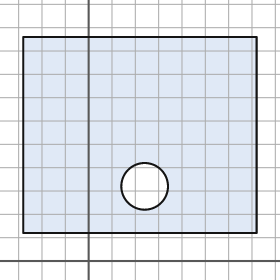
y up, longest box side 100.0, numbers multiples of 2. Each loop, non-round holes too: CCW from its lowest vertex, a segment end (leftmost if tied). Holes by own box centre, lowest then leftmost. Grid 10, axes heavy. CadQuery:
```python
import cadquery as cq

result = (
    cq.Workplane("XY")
    .moveTo(-28.0, 12.0)
    .lineTo(72.0, 12.0)
    .lineTo(72.0, 96.0)
    .lineTo(-28.0, 96.0)
    .close()
    .moveTo(24.0, 32.0)
    .circle(10.0)
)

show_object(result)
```